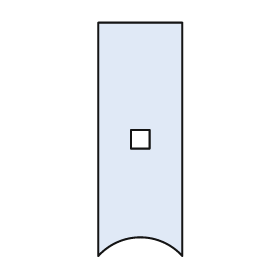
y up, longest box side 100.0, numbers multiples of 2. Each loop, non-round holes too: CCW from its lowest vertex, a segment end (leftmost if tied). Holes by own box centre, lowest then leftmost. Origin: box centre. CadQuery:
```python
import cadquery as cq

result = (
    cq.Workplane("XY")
    .moveTo(-18.0, -50.0)
    .threePointArc((0.0, -42.0), (18.0, -50.0))
    .lineTo(18.0, 50.0)
    .lineTo(-18.0, 50.0)
    .close()
    .moveTo(-4.0, -4.0)
    .lineTo(4.0, -4.0)
    .lineTo(4.0, 4.0)
    .lineTo(-4.0, 4.0)
    .close()
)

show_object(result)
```